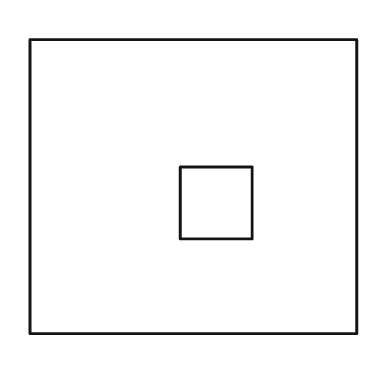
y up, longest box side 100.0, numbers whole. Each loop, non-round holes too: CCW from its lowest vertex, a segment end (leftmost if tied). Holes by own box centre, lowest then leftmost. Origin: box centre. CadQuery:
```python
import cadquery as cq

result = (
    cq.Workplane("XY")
    .moveTo(-50.0, -45.0)
    .lineTo(50.0, -45.0)
    .lineTo(50.0, 45.0)
    .lineTo(-50.0, 45.0)
    .close()
    .moveTo(-4.0, -16.0)
    .lineTo(18.0, -16.0)
    .lineTo(18.0, 6.0)
    .lineTo(-4.0, 6.0)
    .close()
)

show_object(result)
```